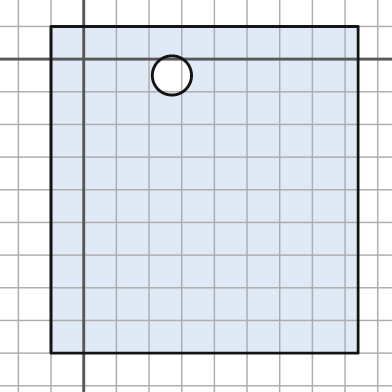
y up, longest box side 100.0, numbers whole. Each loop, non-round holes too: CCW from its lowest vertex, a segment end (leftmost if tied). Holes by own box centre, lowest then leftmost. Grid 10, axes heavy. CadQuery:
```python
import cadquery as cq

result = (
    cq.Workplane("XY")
    .moveTo(-10.0, -90.0)
    .lineTo(84.0, -90.0)
    .lineTo(84.0, 10.0)
    .lineTo(-10.0, 10.0)
    .close()
    .moveTo(27.0, -5.0)
    .circle(6.0)
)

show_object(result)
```